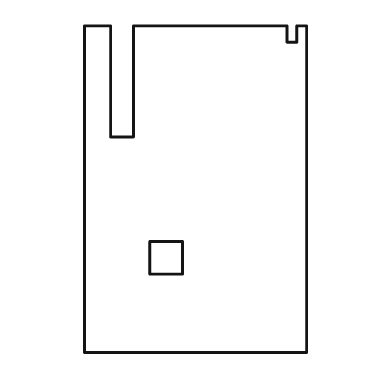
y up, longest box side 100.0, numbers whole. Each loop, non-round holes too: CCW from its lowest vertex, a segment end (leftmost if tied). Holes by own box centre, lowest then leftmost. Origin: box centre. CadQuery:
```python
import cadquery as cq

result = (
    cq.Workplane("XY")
    .moveTo(-34.0, -50.0)
    .lineTo(34.0, -50.0)
    .lineTo(34.0, 50.0)
    .lineTo(31.0, 50.0)
    .lineTo(31.0, 45.0)
    .lineTo(28.0, 45.0)
    .lineTo(28.0, 50.0)
    .lineTo(-19.0, 50.0)
    .lineTo(-19.0, 16.0)
    .lineTo(-26.0, 16.0)
    .lineTo(-26.0, 50.0)
    .lineTo(-34.0, 50.0)
    .close()
    .moveTo(-14.0, -26.0)
    .lineTo(-4.0, -26.0)
    .lineTo(-4.0, -16.0)
    .lineTo(-14.0, -16.0)
    .close()
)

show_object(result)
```